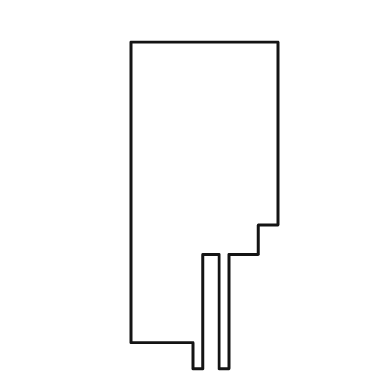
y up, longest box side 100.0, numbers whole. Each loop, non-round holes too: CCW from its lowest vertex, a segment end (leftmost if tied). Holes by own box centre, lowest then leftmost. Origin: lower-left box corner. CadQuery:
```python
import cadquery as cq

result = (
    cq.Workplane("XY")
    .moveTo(19.0, 0.0)
    .lineTo(22.0, 0.0)
    .lineTo(22.0, 35.0)
    .lineTo(27.0, 35.0)
    .lineTo(27.0, 0.0)
    .lineTo(30.0, 0.0)
    .lineTo(30.0, 35.0)
    .lineTo(39.0, 35.0)
    .lineTo(39.0, 44.0)
    .lineTo(45.0, 44.0)
    .lineTo(45.0, 100.0)
    .lineTo(0.0, 100.0)
    .lineTo(0.0, 8.0)
    .lineTo(19.0, 8.0)
    .close()
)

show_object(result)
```